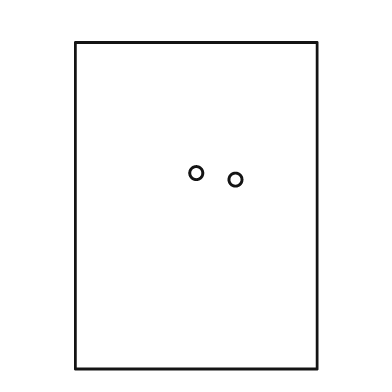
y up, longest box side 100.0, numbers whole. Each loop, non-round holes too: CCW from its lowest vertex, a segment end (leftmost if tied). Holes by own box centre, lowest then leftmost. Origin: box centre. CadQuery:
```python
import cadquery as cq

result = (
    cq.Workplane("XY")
    .moveTo(-37.0, -50.0)
    .lineTo(37.0, -50.0)
    .lineTo(37.0, 50.0)
    .lineTo(-37.0, 50.0)
    .close()
    .moveTo(12.0, 8.0)
    .circle(2.0)
    .moveTo(0.0, 10.0)
    .circle(2.0)
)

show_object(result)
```